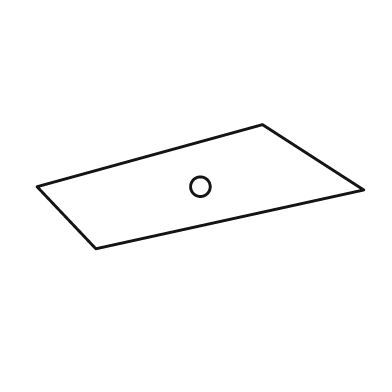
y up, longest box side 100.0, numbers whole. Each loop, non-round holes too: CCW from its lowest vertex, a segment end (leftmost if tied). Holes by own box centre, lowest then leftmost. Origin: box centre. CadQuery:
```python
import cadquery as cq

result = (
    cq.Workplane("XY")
    .moveTo(-32.0, -19.0)
    .lineTo(50.0, -1.0)
    .lineTo(19.0, 19.0)
    .lineTo(-50.0, 0.0)
    .close()
    .moveTo(0.0, 0.0)
    .circle(3.0)
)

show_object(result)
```